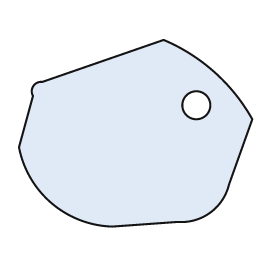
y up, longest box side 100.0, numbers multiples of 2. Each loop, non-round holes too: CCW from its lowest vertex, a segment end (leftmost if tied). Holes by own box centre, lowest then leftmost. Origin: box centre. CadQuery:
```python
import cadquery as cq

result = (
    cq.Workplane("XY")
    .moveTo(-10.0, -40.0)
    .lineTo(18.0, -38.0)
    .threePointArc((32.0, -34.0), (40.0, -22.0))
    .lineTo(50.0, 6.0)
    .threePointArc((34.0, 26.0), (12.0, 40.0))
    .lineTo(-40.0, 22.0)
    .threePointArc((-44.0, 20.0), (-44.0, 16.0))
    .lineTo(-50.0, -6.0)
    .threePointArc((-36.0, -30.0), (-10.0, -40.0))
    .close()
    .moveTo(26.0, 12.0)
    .circle(6.0)
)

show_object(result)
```